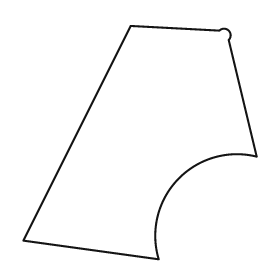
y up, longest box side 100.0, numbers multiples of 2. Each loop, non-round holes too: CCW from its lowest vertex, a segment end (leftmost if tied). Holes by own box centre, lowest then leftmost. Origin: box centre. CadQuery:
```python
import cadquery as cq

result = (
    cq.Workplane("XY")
    .moveTo(8.0, -50.0)
    .threePointArc((16.0, -16.0), (50.0, -6.0))
    .lineTo(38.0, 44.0)
    .threePointArc((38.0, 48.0), (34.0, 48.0))
    .lineTo(-4.0, 50.0)
    .lineTo(-50.0, -42.0)
    .close()
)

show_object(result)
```